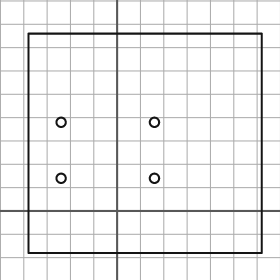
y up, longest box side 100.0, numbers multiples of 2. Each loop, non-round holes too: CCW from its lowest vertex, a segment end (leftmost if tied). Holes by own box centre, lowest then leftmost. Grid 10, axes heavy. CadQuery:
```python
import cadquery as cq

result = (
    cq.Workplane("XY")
    .moveTo(-38.0, -18.0)
    .lineTo(62.0, -18.0)
    .lineTo(62.0, 76.0)
    .lineTo(-38.0, 76.0)
    .close()
    .moveTo(-24.0, 14.0)
    .circle(2.0)
    .moveTo(16.0, 14.0)
    .circle(2.0)
    .moveTo(-24.0, 38.0)
    .circle(2.0)
    .moveTo(16.0, 38.0)
    .circle(2.0)
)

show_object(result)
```